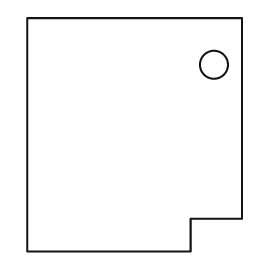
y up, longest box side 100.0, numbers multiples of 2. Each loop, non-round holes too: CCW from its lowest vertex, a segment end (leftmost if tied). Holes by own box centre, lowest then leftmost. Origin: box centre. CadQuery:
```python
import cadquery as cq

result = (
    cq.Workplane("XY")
    .moveTo(-46.0, -50.0)
    .lineTo(24.0, -50.0)
    .lineTo(24.0, -36.0)
    .lineTo(46.0, -36.0)
    .lineTo(46.0, 50.0)
    .lineTo(-46.0, 50.0)
    .close()
    .moveTo(34.0, 30.0)
    .circle(6.0)
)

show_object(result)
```